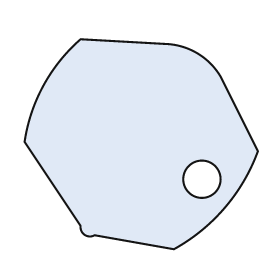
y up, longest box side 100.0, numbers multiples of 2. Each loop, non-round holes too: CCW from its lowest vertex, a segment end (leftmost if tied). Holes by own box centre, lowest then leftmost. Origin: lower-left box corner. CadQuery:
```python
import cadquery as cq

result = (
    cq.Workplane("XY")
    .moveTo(64.0, 0.0)
    .threePointArc((86.0, 18.0), (100.0, 42.0))
    .lineTo(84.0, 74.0)
    .threePointArc((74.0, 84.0), (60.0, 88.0))
    .lineTo(24.0, 90.0)
    .threePointArc((8.0, 70.0), (0.0, 46.0))
    .lineTo(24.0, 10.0)
    .threePointArc((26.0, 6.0), (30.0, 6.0))
    .close()
    .moveTo(76.0, 30.0)
    .circle(8.0)
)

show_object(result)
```